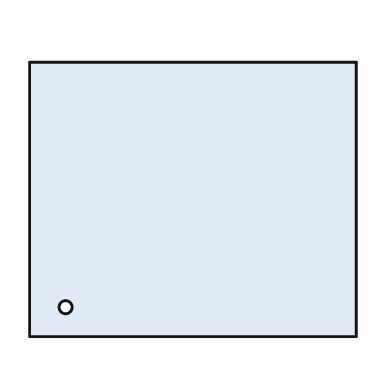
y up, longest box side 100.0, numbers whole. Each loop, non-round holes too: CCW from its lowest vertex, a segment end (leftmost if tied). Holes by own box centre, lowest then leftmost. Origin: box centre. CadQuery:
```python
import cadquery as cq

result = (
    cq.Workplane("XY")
    .moveTo(-50.0, -42.0)
    .lineTo(50.0, -42.0)
    .lineTo(50.0, 42.0)
    .lineTo(-50.0, 42.0)
    .close()
    .moveTo(-39.0, -33.0)
    .circle(2.0)
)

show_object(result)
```